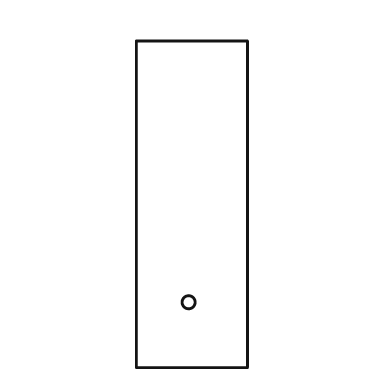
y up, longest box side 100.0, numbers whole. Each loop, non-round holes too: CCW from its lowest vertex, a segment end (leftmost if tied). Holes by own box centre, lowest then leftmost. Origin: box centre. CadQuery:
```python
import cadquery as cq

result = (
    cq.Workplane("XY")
    .moveTo(-17.0, -50.0)
    .lineTo(17.0, -50.0)
    .lineTo(17.0, 50.0)
    .lineTo(-17.0, 50.0)
    .close()
    .moveTo(-1.0, -30.0)
    .circle(2.0)
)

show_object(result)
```